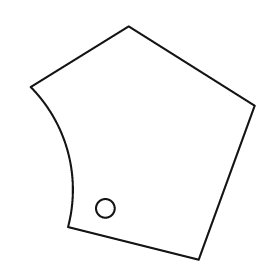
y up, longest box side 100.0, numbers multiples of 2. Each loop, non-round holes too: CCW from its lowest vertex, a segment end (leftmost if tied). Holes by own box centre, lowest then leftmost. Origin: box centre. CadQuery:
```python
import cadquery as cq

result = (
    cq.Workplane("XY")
    .moveTo(24.0, -50.0)
    .lineTo(48.0, 16.0)
    .lineTo(-6.0, 50.0)
    .lineTo(-48.0, 24.0)
    .threePointArc((-32.0, -4.0), (-32.0, -36.0))
    .close()
    .moveTo(-16.0, -28.0)
    .circle(4.0)
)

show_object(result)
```